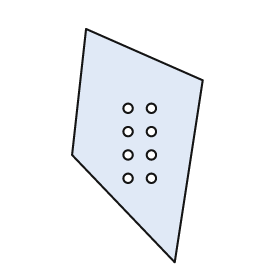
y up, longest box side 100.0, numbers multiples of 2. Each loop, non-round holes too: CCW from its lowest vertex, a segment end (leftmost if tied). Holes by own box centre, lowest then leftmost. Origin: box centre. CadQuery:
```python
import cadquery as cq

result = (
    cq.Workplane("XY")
    .moveTo(16.0, -50.0)
    .lineTo(28.0, 28.0)
    .lineTo(-22.0, 50.0)
    .lineTo(-28.0, -4.0)
    .close()
    .moveTo(-4.0, -14.0)
    .circle(2.0)
    .moveTo(6.0, -14.0)
    .circle(2.0)
    .moveTo(-4.0, -4.0)
    .circle(2.0)
    .moveTo(6.0, -4.0)
    .circle(2.0)
    .moveTo(-4.0, 6.0)
    .circle(2.0)
    .moveTo(6.0, 6.0)
    .circle(2.0)
    .moveTo(-4.0, 16.0)
    .circle(2.0)
    .moveTo(6.0, 16.0)
    .circle(2.0)
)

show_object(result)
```